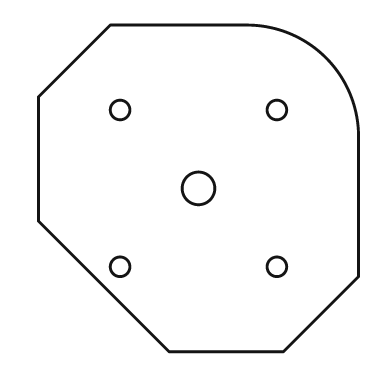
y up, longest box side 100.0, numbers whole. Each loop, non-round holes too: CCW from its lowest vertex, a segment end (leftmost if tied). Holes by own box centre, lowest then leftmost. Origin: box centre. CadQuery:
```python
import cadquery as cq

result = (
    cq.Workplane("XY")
    .moveTo(-9.0, -50.0)
    .lineTo(26.0, -50.0)
    .lineTo(49.0, -27.0)
    .lineTo(49.0, 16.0)
    .threePointArc((39.0, 40.0), (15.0, 50.0))
    .lineTo(-27.0, 50.0)
    .lineTo(-49.0, 28.0)
    .lineTo(-49.0, -10.0)
    .close()
    .moveTo(-24.0, -24.0)
    .circle(3.0)
    .moveTo(24.0, -24.0)
    .circle(3.0)
    .moveTo(0.0, 0.0)
    .circle(5.0)
    .moveTo(-24.0, 24.0)
    .circle(3.0)
    .moveTo(24.0, 24.0)
    .circle(3.0)
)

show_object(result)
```